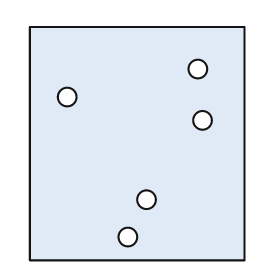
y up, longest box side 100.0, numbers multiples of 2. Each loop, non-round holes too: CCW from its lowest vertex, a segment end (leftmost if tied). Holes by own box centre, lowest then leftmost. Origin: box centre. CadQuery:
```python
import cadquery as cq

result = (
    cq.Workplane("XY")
    .moveTo(-46.0, -50.0)
    .lineTo(46.0, -50.0)
    .lineTo(46.0, 50.0)
    .lineTo(-46.0, 50.0)
    .close()
    .moveTo(-4.0, -40.0)
    .circle(4.0)
    .moveTo(4.0, -24.0)
    .circle(4.0)
    .moveTo(28.0, 10.0)
    .circle(4.0)
    .moveTo(-30.0, 20.0)
    .circle(4.0)
    .moveTo(26.0, 32.0)
    .circle(4.0)
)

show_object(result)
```